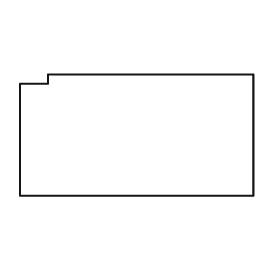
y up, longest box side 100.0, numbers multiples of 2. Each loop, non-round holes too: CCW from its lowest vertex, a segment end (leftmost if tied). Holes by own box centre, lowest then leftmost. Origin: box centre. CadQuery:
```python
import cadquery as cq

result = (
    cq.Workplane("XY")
    .moveTo(-50.0, -26.0)
    .lineTo(50.0, -26.0)
    .lineTo(50.0, 26.0)
    .lineTo(-38.0, 26.0)
    .lineTo(-38.0, 22.0)
    .lineTo(-50.0, 22.0)
    .close()
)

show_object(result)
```